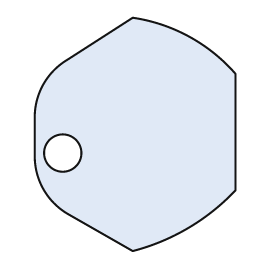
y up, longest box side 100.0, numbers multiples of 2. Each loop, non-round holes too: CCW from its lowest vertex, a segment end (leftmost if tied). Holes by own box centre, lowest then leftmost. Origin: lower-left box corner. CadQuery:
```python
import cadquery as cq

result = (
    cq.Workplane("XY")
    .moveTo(42.0, 0.0)
    .threePointArc((66.0, 10.0), (86.0, 26.0))
    .lineTo(86.0, 76.0)
    .threePointArc((66.0, 92.0), (42.0, 100.0))
    .lineTo(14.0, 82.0)
    .threePointArc((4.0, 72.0), (0.0, 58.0))
    .lineTo(0.0, 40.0)
    .threePointArc((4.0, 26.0), (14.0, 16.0))
    .close()
    .moveTo(12.0, 42.0)
    .circle(8.0)
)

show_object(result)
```